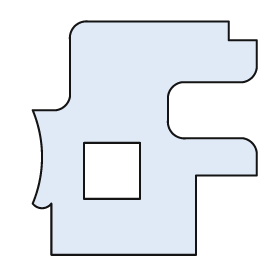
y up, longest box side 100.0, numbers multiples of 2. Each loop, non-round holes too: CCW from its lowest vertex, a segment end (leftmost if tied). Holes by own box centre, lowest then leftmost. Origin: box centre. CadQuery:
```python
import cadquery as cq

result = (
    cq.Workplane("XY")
    .moveTo(-40.0, -50.0)
    .lineTo(22.0, -50.0)
    .lineTo(22.0, -16.0)
    .lineTo(48.0, -16.0)
    .lineTo(48.0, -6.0)
    .threePointArc((46.0, -2.0), (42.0, 0.0))
    .lineTo(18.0, 0.0)
    .threePointArc((12.0, 2.0), (10.0, 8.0))
    .lineTo(10.0, 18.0)
    .threePointArc((12.0, 22.0), (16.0, 24.0))
    .lineTo(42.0, 24.0)
    .threePointArc((46.0, 26.0), (48.0, 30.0))
    .lineTo(48.0, 42.0)
    .lineTo(36.0, 42.0)
    .lineTo(36.0, 50.0)
    .lineTo(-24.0, 50.0)
    .threePointArc((-30.0, 48.0), (-32.0, 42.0))
    .lineTo(-32.0, 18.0)
    .threePointArc((-34.0, 14.0), (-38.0, 12.0))
    .lineTo(-48.0, 12.0)
    .threePointArc((-44.0, -8.0), (-48.0, -28.0))
    .threePointArc((-44.0, -30.0), (-40.0, -28.0))
    .close()
    .moveTo(-26.0, -26.0)
    .lineTo(-2.0, -26.0)
    .lineTo(-2.0, -2.0)
    .lineTo(-26.0, -2.0)
    .close()
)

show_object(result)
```